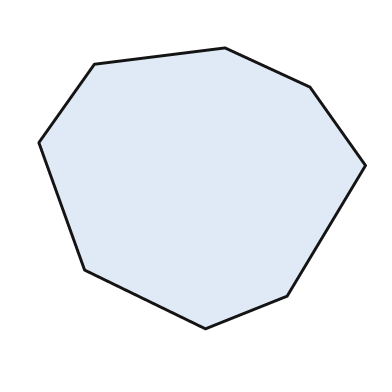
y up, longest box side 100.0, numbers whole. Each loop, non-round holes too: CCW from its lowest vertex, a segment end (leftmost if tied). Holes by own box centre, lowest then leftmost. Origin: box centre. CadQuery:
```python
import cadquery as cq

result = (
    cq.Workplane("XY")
    .moveTo(1.0, -43.0)
    .lineTo(26.0, -33.0)
    .lineTo(50.0, 7.0)
    .lineTo(33.0, 31.0)
    .lineTo(7.0, 43.0)
    .lineTo(-33.0, 38.0)
    .lineTo(-50.0, 14.0)
    .lineTo(-36.0, -25.0)
    .close()
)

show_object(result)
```